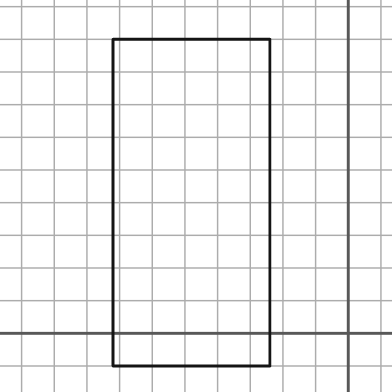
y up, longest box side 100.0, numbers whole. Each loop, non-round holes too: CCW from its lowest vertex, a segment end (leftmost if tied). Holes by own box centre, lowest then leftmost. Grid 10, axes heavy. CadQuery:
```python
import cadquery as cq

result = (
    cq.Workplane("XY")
    .moveTo(-72.0, -10.0)
    .lineTo(-24.0, -10.0)
    .lineTo(-24.0, 90.0)
    .lineTo(-72.0, 90.0)
    .close()
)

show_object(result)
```